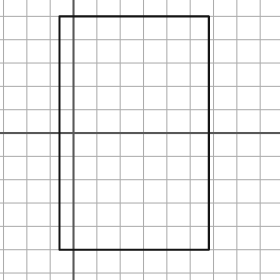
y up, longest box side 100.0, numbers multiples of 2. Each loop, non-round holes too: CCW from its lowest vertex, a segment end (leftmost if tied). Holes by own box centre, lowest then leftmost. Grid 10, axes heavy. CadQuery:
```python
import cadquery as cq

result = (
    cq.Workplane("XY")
    .moveTo(-6.0, -50.0)
    .lineTo(58.0, -50.0)
    .lineTo(58.0, 50.0)
    .lineTo(-6.0, 50.0)
    .close()
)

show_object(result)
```